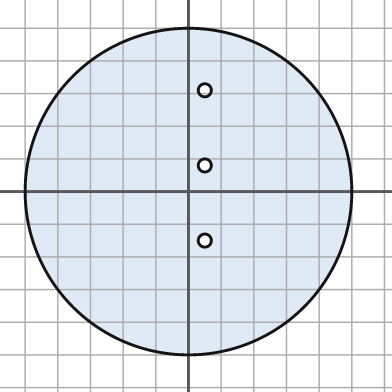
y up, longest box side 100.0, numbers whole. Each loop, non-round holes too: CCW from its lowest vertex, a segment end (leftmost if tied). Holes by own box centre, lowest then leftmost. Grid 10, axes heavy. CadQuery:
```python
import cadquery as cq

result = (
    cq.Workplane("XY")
    .moveTo(0.0, 0.0)
    .circle(50.0)
    .moveTo(5.0, -15.0)
    .circle(2.0)
    .moveTo(5.0, 8.0)
    .circle(2.0)
    .moveTo(5.0, 31.0)
    .circle(2.0)
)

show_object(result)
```